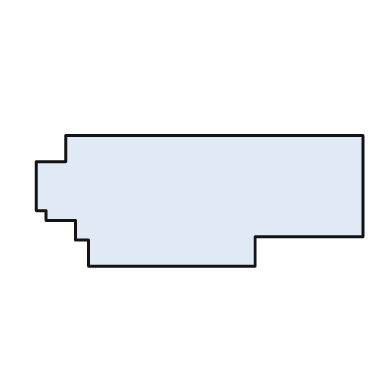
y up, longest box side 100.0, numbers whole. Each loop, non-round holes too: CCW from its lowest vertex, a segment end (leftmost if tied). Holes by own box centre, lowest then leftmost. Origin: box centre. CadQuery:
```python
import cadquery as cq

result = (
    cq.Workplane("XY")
    .moveTo(-34.0, -20.0)
    .lineTo(17.0, -20.0)
    .lineTo(17.0, -11.0)
    .lineTo(50.0, -11.0)
    .lineTo(50.0, 20.0)
    .lineTo(-41.0, 20.0)
    .lineTo(-41.0, 12.0)
    .lineTo(-50.0, 12.0)
    .lineTo(-50.0, -3.0)
    .lineTo(-47.0, -3.0)
    .lineTo(-47.0, -6.0)
    .lineTo(-38.0, -6.0)
    .lineTo(-38.0, -12.0)
    .lineTo(-34.0, -12.0)
    .close()
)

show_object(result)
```